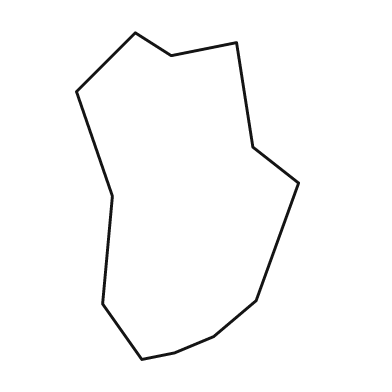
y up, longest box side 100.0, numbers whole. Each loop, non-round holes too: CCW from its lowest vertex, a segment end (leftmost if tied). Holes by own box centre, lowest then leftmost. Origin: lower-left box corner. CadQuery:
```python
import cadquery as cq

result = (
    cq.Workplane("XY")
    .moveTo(20.0, 0.0)
    .lineTo(30.0, 2.0)
    .lineTo(42.0, 7.0)
    .lineTo(55.0, 18.0)
    .lineTo(68.0, 54.0)
    .lineTo(54.0, 65.0)
    .lineTo(49.0, 97.0)
    .lineTo(29.0, 93.0)
    .lineTo(18.0, 100.0)
    .lineTo(0.0, 82.0)
    .lineTo(11.0, 50.0)
    .lineTo(8.0, 17.0)
    .close()
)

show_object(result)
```